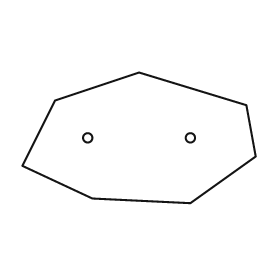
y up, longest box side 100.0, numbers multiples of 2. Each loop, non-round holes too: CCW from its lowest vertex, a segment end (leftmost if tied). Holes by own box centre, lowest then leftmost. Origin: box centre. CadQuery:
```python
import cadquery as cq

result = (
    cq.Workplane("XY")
    .moveTo(22.0, -28.0)
    .lineTo(50.0, -8.0)
    .lineTo(46.0, 14.0)
    .lineTo(0.0, 28.0)
    .lineTo(-36.0, 16.0)
    .lineTo(-50.0, -12.0)
    .lineTo(-20.0, -26.0)
    .close()
    .moveTo(-22.0, 0.0)
    .circle(2.0)
    .moveTo(22.0, 0.0)
    .circle(2.0)
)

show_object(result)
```